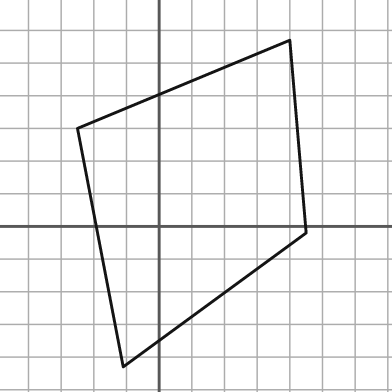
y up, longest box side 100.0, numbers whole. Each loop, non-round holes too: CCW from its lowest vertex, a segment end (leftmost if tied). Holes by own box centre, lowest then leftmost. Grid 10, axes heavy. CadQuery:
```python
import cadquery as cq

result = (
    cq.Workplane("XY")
    .moveTo(-11.0, -43.0)
    .lineTo(45.0, -2.0)
    .lineTo(40.0, 57.0)
    .lineTo(-25.0, 30.0)
    .close()
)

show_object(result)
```